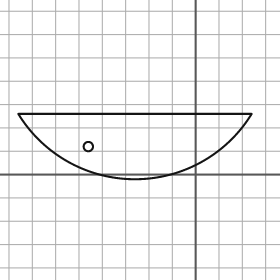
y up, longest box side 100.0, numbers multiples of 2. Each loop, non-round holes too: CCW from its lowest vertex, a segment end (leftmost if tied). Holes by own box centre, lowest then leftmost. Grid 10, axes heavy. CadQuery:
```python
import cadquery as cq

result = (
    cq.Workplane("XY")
    .moveTo(-76.0, 26.0)
    .threePointArc((-26.0, -2.0), (24.0, 26.0))
    .close()
    .moveTo(-46.0, 12.0)
    .circle(2.0)
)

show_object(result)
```